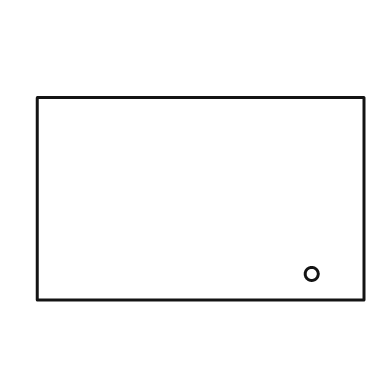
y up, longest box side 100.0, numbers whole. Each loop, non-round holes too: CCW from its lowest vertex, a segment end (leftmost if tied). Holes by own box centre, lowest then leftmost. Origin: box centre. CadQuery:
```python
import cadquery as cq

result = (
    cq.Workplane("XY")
    .moveTo(-50.0, -31.0)
    .lineTo(50.0, -31.0)
    .lineTo(50.0, 31.0)
    .lineTo(-50.0, 31.0)
    .close()
    .moveTo(34.0, -23.0)
    .circle(2.0)
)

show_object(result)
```